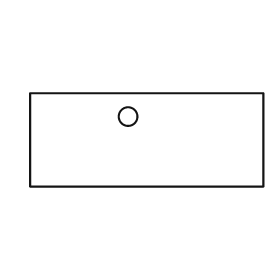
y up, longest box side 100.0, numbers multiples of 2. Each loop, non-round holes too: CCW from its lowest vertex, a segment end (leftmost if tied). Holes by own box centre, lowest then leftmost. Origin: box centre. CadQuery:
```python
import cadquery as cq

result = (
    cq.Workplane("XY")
    .moveTo(-50.0, -20.0)
    .lineTo(50.0, -20.0)
    .lineTo(50.0, 20.0)
    .lineTo(-50.0, 20.0)
    .close()
    .moveTo(-8.0, 10.0)
    .circle(4.0)
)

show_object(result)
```